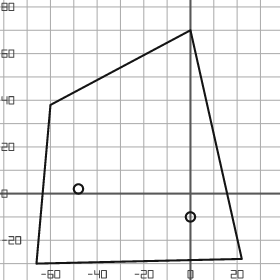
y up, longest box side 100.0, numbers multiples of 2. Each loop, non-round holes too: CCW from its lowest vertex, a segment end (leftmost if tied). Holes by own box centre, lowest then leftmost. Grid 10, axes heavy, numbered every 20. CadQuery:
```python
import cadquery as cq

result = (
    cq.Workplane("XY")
    .moveTo(-66.0, -30.0)
    .lineTo(22.0, -28.0)
    .lineTo(0.0, 70.0)
    .lineTo(-60.0, 38.0)
    .close()
    .moveTo(0.0, -10.0)
    .circle(2.0)
    .moveTo(-48.0, 2.0)
    .circle(2.0)
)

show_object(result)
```